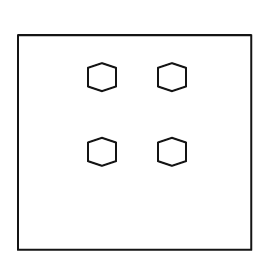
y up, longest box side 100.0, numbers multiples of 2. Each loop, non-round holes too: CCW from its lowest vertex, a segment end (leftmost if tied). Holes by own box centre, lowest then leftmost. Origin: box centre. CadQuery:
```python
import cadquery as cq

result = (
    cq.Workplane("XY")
    .moveTo(-50.0, -46.0)
    .lineTo(50.0, -46.0)
    .lineTo(50.0, 46.0)
    .lineTo(-50.0, 46.0)
    .close()
    .moveTo(-14.0, -10.0)
    .lineTo(-8.0, -8.0)
    .lineTo(-8.0, 0.0)
    .lineTo(-14.0, 2.0)
    .lineTo(-20.0, 0.0)
    .lineTo(-20.0, -8.0)
    .close()
    .moveTo(16.0, -10.0)
    .lineTo(22.0, -8.0)
    .lineTo(22.0, 0.0)
    .lineTo(16.0, 2.0)
    .lineTo(10.0, 0.0)
    .lineTo(10.0, -8.0)
    .close()
    .moveTo(-14.0, 22.0)
    .lineTo(-8.0, 24.0)
    .lineTo(-8.0, 32.0)
    .lineTo(-14.0, 34.0)
    .lineTo(-20.0, 32.0)
    .lineTo(-20.0, 24.0)
    .close()
    .moveTo(16.0, 22.0)
    .lineTo(22.0, 24.0)
    .lineTo(22.0, 32.0)
    .lineTo(16.0, 34.0)
    .lineTo(10.0, 32.0)
    .lineTo(10.0, 24.0)
    .close()
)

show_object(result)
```